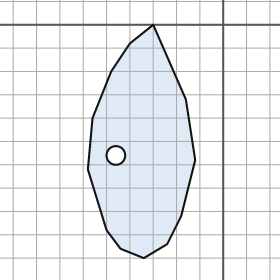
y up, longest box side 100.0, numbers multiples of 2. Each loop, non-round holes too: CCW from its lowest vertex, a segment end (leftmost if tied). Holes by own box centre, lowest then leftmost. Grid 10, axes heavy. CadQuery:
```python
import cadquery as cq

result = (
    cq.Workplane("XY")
    .moveTo(-34.0, -100.0)
    .lineTo(-24.0, -94.0)
    .lineTo(-18.0, -82.0)
    .lineTo(-12.0, -58.0)
    .lineTo(-16.0, -32.0)
    .lineTo(-30.0, 0.0)
    .lineTo(-40.0, -8.0)
    .lineTo(-48.0, -20.0)
    .lineTo(-56.0, -40.0)
    .lineTo(-58.0, -62.0)
    .lineTo(-50.0, -88.0)
    .lineTo(-44.0, -96.0)
    .close()
    .moveTo(-46.0, -56.0)
    .circle(4.0)
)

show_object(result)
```